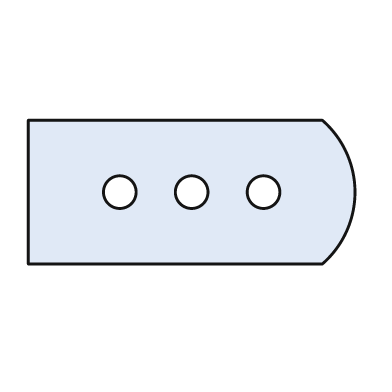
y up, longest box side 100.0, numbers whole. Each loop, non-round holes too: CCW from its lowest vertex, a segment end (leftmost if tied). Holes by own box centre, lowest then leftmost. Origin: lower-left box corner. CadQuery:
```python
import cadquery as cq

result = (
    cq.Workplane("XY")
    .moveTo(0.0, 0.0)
    .lineTo(90.0, 0.0)
    .threePointArc((100.0, 22.0), (90.0, 44.0))
    .lineTo(0.0, 44.0)
    .close()
    .moveTo(28.0, 22.0)
    .circle(5.0)
    .moveTo(50.0, 22.0)
    .circle(5.0)
    .moveTo(72.0, 22.0)
    .circle(5.0)
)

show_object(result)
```